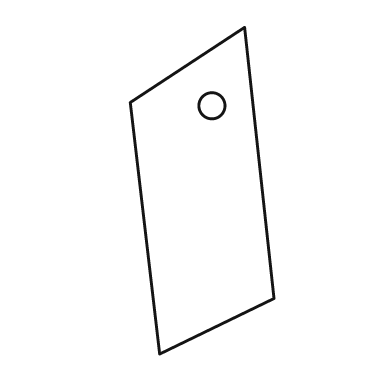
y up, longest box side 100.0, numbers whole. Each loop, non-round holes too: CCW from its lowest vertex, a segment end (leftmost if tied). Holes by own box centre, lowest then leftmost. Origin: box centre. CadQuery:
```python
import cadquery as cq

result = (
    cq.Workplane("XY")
    .moveTo(-13.0, -50.0)
    .lineTo(22.0, -33.0)
    .lineTo(13.0, 50.0)
    .lineTo(-22.0, 27.0)
    .close()
    .moveTo(3.0, 26.0)
    .circle(4.0)
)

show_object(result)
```